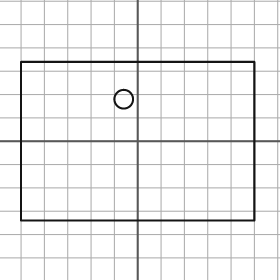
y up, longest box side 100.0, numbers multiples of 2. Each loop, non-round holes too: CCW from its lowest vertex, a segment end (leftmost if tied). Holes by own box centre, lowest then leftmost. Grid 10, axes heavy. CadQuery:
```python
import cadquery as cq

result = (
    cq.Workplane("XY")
    .moveTo(-50.0, -34.0)
    .lineTo(50.0, -34.0)
    .lineTo(50.0, 34.0)
    .lineTo(-50.0, 34.0)
    .close()
    .moveTo(-6.0, 18.0)
    .circle(4.0)
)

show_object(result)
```